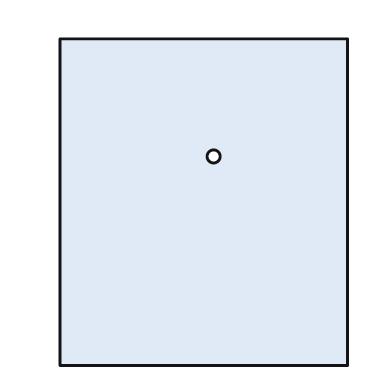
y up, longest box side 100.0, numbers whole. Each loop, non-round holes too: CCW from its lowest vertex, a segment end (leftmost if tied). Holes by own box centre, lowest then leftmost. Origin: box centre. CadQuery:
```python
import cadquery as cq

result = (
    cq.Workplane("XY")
    .moveTo(-44.0, -50.0)
    .lineTo(44.0, -50.0)
    .lineTo(44.0, 50.0)
    .lineTo(-44.0, 50.0)
    .close()
    .moveTo(3.0, 14.0)
    .circle(2.0)
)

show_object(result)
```